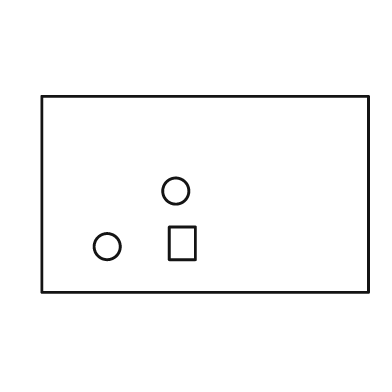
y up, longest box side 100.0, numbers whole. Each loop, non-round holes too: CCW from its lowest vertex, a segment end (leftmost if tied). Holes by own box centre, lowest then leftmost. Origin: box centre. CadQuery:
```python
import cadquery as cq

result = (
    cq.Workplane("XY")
    .moveTo(-50.0, -30.0)
    .lineTo(50.0, -30.0)
    .lineTo(50.0, 30.0)
    .lineTo(-50.0, 30.0)
    .close()
    .moveTo(-30.0, -16.0)
    .circle(4.0)
    .moveTo(-11.0, -20.0)
    .lineTo(-3.0, -20.0)
    .lineTo(-3.0, -10.0)
    .lineTo(-11.0, -10.0)
    .close()
    .moveTo(-9.0, 1.0)
    .circle(4.0)
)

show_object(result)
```